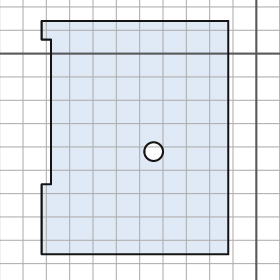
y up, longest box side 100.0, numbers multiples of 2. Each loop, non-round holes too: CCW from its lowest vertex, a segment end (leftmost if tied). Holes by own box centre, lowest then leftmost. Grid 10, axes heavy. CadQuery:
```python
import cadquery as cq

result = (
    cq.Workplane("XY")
    .moveTo(-92.0, -86.0)
    .lineTo(-12.0, -86.0)
    .lineTo(-12.0, 14.0)
    .lineTo(-92.0, 14.0)
    .lineTo(-92.0, 6.0)
    .lineTo(-88.0, 6.0)
    .lineTo(-88.0, -56.0)
    .lineTo(-92.0, -56.0)
    .close()
    .moveTo(-44.0, -42.0)
    .circle(4.0)
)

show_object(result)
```